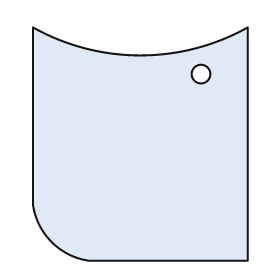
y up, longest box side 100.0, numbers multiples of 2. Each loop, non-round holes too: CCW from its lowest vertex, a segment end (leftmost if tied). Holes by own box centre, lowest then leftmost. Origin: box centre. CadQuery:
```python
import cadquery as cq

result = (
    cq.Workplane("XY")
    .moveTo(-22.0, -50.0)
    .lineTo(46.0, -50.0)
    .lineTo(46.0, 50.0)
    .threePointArc((0.0, 38.0), (-46.0, 50.0))
    .lineTo(-46.0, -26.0)
    .threePointArc((-38.0, -42.0), (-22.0, -50.0))
    .close()
    .moveTo(26.0, 30.0)
    .circle(4.0)
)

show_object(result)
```